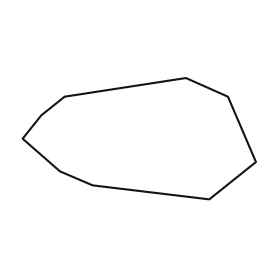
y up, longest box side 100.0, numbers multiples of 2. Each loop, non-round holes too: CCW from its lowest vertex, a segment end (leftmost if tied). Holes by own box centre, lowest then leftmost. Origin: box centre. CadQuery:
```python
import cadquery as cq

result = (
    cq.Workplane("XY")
    .moveTo(30.0, -26.0)
    .lineTo(50.0, -10.0)
    .lineTo(38.0, 18.0)
    .lineTo(20.0, 26.0)
    .lineTo(-32.0, 18.0)
    .lineTo(-42.0, 10.0)
    .lineTo(-50.0, 0.0)
    .lineTo(-34.0, -14.0)
    .lineTo(-20.0, -20.0)
    .close()
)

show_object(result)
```